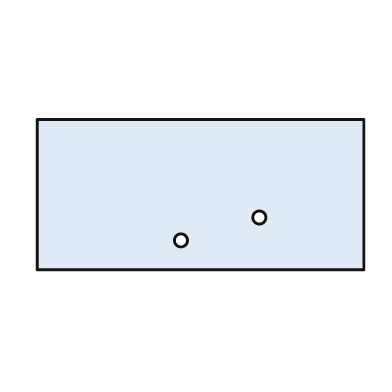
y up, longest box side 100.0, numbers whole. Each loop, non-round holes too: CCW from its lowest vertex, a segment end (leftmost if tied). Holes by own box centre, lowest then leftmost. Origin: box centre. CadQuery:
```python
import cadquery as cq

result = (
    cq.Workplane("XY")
    .moveTo(-50.0, -23.0)
    .lineTo(50.0, -23.0)
    .lineTo(50.0, 23.0)
    .lineTo(-50.0, 23.0)
    .close()
    .moveTo(-6.0, -14.0)
    .circle(2.0)
    .moveTo(18.0, -7.0)
    .circle(2.0)
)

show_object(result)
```